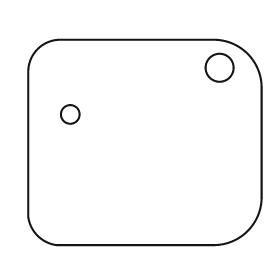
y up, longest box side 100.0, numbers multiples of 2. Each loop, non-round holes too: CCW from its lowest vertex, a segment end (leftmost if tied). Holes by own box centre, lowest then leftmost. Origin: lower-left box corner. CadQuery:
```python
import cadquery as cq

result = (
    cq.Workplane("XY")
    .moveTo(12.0, 0.0)
    .lineTo(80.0, 0.0)
    .threePointArc((94.0, 6.0), (100.0, 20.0))
    .lineTo(100.0, 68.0)
    .threePointArc((94.0, 82.0), (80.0, 88.0))
    .lineTo(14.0, 88.0)
    .threePointArc((4.0, 84.0), (0.0, 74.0))
    .lineTo(0.0, 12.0)
    .threePointArc((4.0, 4.0), (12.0, 0.0))
    .close()
    .moveTo(18.0, 56.0)
    .circle(4.0)
    .moveTo(82.0, 76.0)
    .circle(6.0)
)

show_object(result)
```